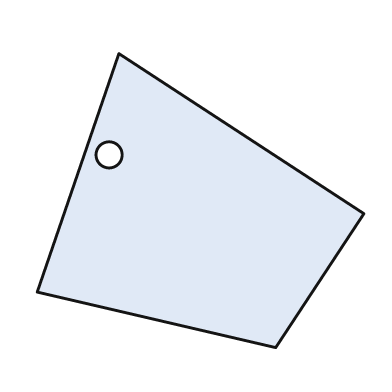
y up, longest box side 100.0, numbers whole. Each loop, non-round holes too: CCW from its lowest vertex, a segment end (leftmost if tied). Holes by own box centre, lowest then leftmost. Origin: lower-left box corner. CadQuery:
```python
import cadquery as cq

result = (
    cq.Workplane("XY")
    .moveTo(73.0, 0.0)
    .lineTo(100.0, 41.0)
    .lineTo(25.0, 90.0)
    .lineTo(0.0, 17.0)
    .close()
    .moveTo(22.0, 59.0)
    .circle(4.0)
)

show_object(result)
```